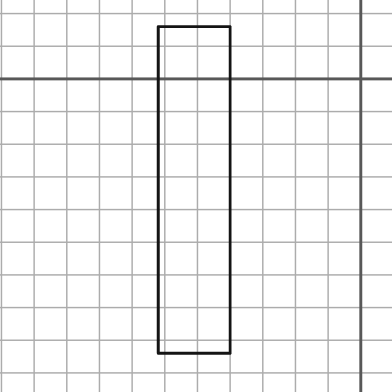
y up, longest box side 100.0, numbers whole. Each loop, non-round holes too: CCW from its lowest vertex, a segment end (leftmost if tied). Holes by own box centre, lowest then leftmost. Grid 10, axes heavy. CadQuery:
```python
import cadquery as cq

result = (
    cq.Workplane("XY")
    .moveTo(-62.0, -84.0)
    .lineTo(-40.0, -84.0)
    .lineTo(-40.0, 16.0)
    .lineTo(-62.0, 16.0)
    .close()
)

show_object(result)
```